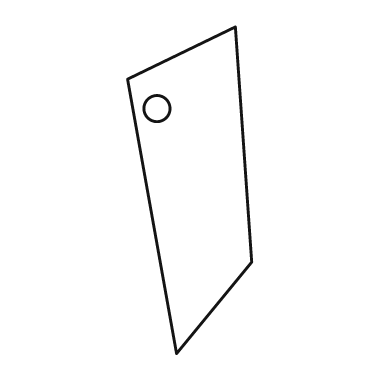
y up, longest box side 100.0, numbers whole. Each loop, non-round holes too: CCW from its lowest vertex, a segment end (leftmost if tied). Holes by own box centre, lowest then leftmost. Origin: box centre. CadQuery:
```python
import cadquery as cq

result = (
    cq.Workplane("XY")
    .moveTo(-4.0, -50.0)
    .lineTo(19.0, -22.0)
    .lineTo(14.0, 50.0)
    .lineTo(-19.0, 34.0)
    .close()
    .moveTo(-10.0, 25.0)
    .circle(4.0)
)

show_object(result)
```